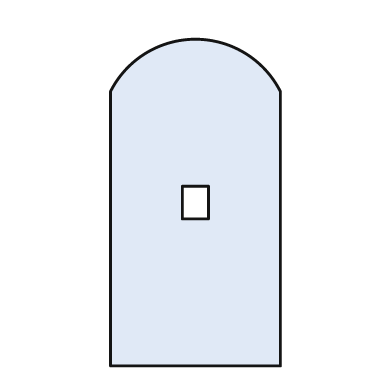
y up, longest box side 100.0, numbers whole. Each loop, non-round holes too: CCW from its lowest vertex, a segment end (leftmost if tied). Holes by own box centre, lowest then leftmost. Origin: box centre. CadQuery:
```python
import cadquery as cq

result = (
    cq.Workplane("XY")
    .moveTo(-26.0, -50.0)
    .lineTo(26.0, -50.0)
    .lineTo(26.0, 34.0)
    .threePointArc((0.0, 50.0), (-26.0, 34.0))
    .close()
    .moveTo(-4.0, -5.0)
    .lineTo(4.0, -5.0)
    .lineTo(4.0, 5.0)
    .lineTo(-4.0, 5.0)
    .close()
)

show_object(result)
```